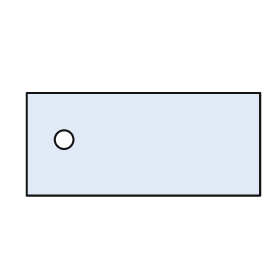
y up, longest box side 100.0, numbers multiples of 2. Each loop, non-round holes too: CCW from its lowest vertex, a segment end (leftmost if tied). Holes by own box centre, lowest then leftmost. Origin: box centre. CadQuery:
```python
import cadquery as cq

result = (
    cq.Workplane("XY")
    .moveTo(-50.0, -22.0)
    .lineTo(50.0, -22.0)
    .lineTo(50.0, 22.0)
    .lineTo(-50.0, 22.0)
    .close()
    .moveTo(-34.0, 2.0)
    .circle(4.0)
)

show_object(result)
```